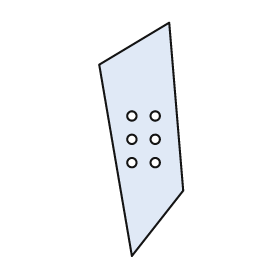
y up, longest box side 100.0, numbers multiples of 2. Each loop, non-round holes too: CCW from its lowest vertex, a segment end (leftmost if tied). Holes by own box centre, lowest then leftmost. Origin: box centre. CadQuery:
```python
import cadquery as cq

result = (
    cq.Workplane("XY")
    .moveTo(-4.0, -50.0)
    .lineTo(18.0, -22.0)
    .lineTo(12.0, 50.0)
    .lineTo(-18.0, 32.0)
    .close()
    .moveTo(-4.0, -10.0)
    .circle(2.0)
    .moveTo(6.0, -10.0)
    .circle(2.0)
    .moveTo(-4.0, 0.0)
    .circle(2.0)
    .moveTo(6.0, 0.0)
    .circle(2.0)
    .moveTo(-4.0, 10.0)
    .circle(2.0)
    .moveTo(6.0, 10.0)
    .circle(2.0)
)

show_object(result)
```